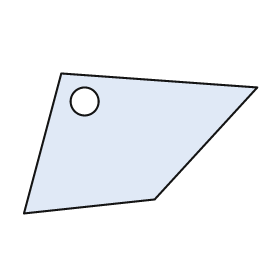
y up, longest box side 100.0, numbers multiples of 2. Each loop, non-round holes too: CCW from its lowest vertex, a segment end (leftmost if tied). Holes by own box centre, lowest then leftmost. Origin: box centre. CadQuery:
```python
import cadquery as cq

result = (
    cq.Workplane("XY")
    .moveTo(-50.0, -30.0)
    .lineTo(6.0, -24.0)
    .lineTo(50.0, 24.0)
    .lineTo(-34.0, 30.0)
    .close()
    .moveTo(-24.0, 18.0)
    .circle(6.0)
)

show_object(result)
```